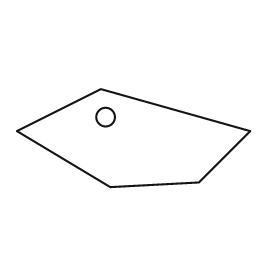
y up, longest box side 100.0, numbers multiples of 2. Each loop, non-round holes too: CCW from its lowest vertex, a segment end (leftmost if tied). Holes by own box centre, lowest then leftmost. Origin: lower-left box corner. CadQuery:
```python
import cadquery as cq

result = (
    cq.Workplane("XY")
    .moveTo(40.0, 0.0)
    .lineTo(78.0, 2.0)
    .lineTo(100.0, 24.0)
    .lineTo(36.0, 42.0)
    .lineTo(0.0, 24.0)
    .close()
    .moveTo(38.0, 30.0)
    .circle(4.0)
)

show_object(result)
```